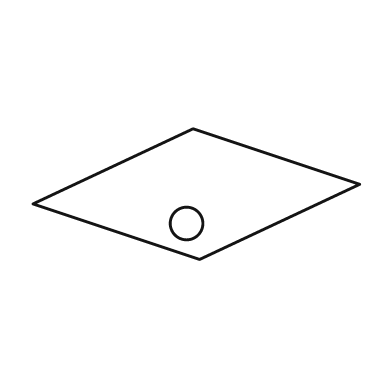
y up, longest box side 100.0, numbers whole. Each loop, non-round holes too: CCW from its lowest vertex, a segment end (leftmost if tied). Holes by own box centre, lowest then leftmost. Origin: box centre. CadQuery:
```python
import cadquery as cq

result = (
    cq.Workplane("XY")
    .moveTo(1.0, -20.0)
    .lineTo(50.0, 3.0)
    .lineTo(-1.0, 20.0)
    .lineTo(-50.0, -3.0)
    .close()
    .moveTo(-3.0, -9.0)
    .circle(5.0)
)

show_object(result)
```